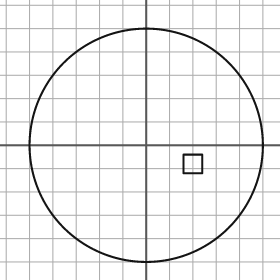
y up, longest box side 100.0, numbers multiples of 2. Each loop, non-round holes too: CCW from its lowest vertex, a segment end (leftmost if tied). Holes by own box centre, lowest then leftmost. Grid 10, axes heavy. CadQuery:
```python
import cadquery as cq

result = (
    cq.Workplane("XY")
    .moveTo(0.0, 0.0)
    .circle(50.0)
    .moveTo(16.0, -12.0)
    .lineTo(24.0, -12.0)
    .lineTo(24.0, -4.0)
    .lineTo(16.0, -4.0)
    .close()
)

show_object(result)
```